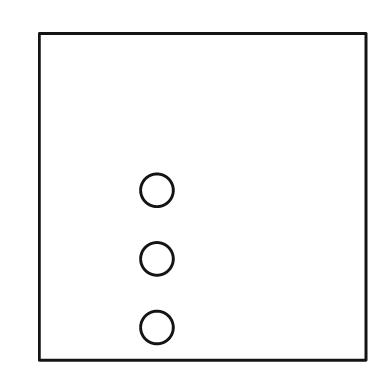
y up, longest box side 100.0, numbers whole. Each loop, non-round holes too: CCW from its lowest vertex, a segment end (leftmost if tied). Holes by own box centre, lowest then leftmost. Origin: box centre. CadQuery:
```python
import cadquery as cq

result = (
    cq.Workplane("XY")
    .moveTo(-50.0, -50.0)
    .lineTo(50.0, -50.0)
    .lineTo(50.0, 50.0)
    .lineTo(-50.0, 50.0)
    .close()
    .moveTo(-14.0, -40.0)
    .circle(5.0)
    .moveTo(-14.0, -19.0)
    .circle(5.0)
    .moveTo(-14.0, 2.0)
    .circle(5.0)
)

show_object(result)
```